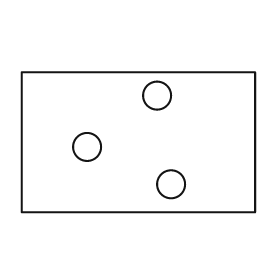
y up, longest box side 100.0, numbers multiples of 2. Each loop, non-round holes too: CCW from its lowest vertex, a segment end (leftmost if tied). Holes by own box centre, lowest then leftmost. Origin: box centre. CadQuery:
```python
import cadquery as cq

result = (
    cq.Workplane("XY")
    .moveTo(-50.0, -30.0)
    .lineTo(50.0, -30.0)
    .lineTo(50.0, 30.0)
    .lineTo(-50.0, 30.0)
    .close()
    .moveTo(14.0, -18.0)
    .circle(6.0)
    .moveTo(-22.0, -2.0)
    .circle(6.0)
    .moveTo(8.0, 20.0)
    .circle(6.0)
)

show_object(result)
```